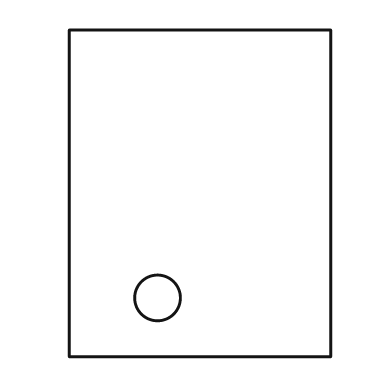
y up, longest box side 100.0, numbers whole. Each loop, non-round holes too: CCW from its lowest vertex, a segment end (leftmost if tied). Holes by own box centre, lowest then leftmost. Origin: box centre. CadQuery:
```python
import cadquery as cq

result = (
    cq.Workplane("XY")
    .moveTo(-40.0, -50.0)
    .lineTo(40.0, -50.0)
    .lineTo(40.0, 50.0)
    .lineTo(-40.0, 50.0)
    .close()
    .moveTo(-13.0, -32.0)
    .circle(7.0)
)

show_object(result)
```